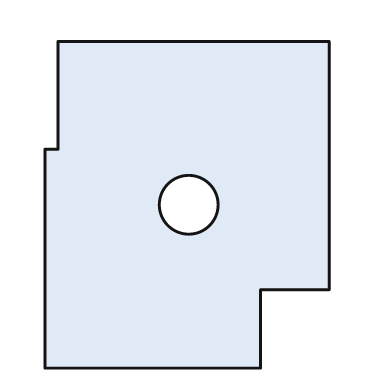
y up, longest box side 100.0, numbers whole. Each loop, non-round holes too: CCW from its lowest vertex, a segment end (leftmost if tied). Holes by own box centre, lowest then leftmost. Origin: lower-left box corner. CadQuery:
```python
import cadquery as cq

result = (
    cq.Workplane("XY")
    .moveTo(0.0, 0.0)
    .lineTo(66.0, 0.0)
    .lineTo(66.0, 24.0)
    .lineTo(87.0, 24.0)
    .lineTo(87.0, 100.0)
    .lineTo(4.0, 100.0)
    .lineTo(4.0, 67.0)
    .lineTo(0.0, 67.0)
    .close()
    .moveTo(44.0, 50.0)
    .circle(9.0)
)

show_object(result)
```